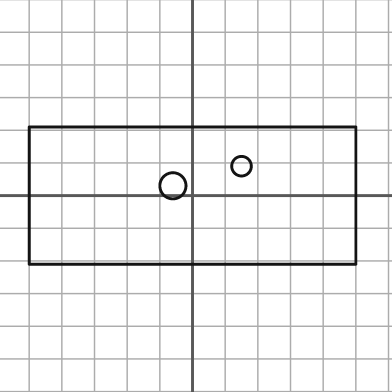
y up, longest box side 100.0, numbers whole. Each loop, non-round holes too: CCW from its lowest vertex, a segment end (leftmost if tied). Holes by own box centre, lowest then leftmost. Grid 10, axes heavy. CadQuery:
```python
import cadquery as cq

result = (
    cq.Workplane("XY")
    .moveTo(-50.0, -21.0)
    .lineTo(50.0, -21.0)
    .lineTo(50.0, 21.0)
    .lineTo(-50.0, 21.0)
    .close()
    .moveTo(-6.0, 3.0)
    .circle(4.0)
    .moveTo(15.0, 9.0)
    .circle(3.0)
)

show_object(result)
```